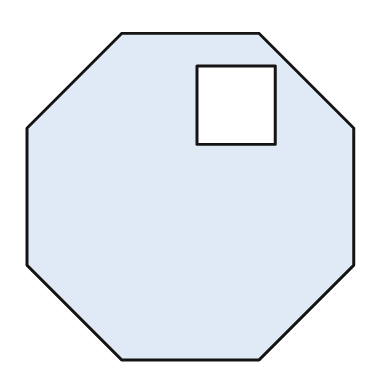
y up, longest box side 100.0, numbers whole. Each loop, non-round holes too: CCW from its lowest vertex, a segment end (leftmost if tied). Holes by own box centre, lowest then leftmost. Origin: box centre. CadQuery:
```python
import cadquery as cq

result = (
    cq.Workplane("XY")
    .moveTo(-21.0, -50.0)
    .lineTo(21.0, -50.0)
    .lineTo(50.0, -21.0)
    .lineTo(50.0, 21.0)
    .lineTo(21.0, 50.0)
    .lineTo(-21.0, 50.0)
    .lineTo(-50.0, 21.0)
    .lineTo(-50.0, -21.0)
    .close()
    .moveTo(2.0, 16.0)
    .lineTo(26.0, 16.0)
    .lineTo(26.0, 40.0)
    .lineTo(2.0, 40.0)
    .close()
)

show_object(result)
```